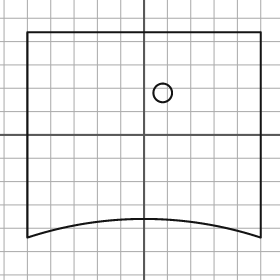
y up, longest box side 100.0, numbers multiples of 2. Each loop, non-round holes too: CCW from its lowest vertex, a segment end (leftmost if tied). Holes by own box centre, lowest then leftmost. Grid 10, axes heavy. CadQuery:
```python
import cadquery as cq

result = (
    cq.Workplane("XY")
    .moveTo(-50.0, -44.0)
    .threePointArc((0.0, -36.0), (50.0, -44.0))
    .lineTo(50.0, 44.0)
    .lineTo(-50.0, 44.0)
    .close()
    .moveTo(8.0, 18.0)
    .circle(4.0)
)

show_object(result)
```